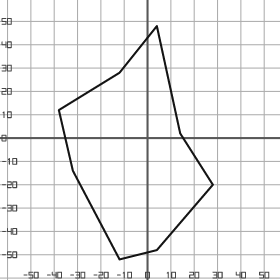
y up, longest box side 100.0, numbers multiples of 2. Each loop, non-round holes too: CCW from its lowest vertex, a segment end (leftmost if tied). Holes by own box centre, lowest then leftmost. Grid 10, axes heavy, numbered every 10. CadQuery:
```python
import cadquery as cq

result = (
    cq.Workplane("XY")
    .moveTo(-12.0, -52.0)
    .lineTo(4.0, -48.0)
    .lineTo(28.0, -20.0)
    .lineTo(14.0, 2.0)
    .lineTo(4.0, 48.0)
    .lineTo(-12.0, 28.0)
    .lineTo(-38.0, 12.0)
    .lineTo(-32.0, -14.0)
    .close()
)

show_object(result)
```